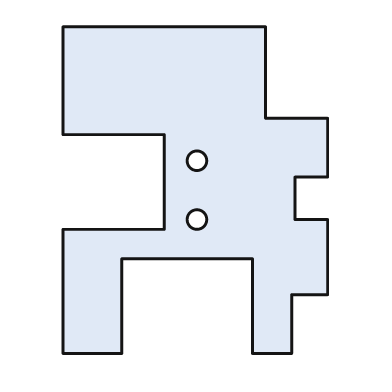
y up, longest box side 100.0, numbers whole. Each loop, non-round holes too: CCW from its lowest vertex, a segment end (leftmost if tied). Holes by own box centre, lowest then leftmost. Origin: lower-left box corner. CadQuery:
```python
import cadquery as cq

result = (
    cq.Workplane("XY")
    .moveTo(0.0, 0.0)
    .lineTo(18.0, 0.0)
    .lineTo(18.0, 29.0)
    .lineTo(58.0, 29.0)
    .lineTo(58.0, 0.0)
    .lineTo(70.0, 0.0)
    .lineTo(70.0, 18.0)
    .lineTo(81.0, 18.0)
    .lineTo(81.0, 41.0)
    .lineTo(71.0, 41.0)
    .lineTo(71.0, 54.0)
    .lineTo(81.0, 54.0)
    .lineTo(81.0, 72.0)
    .lineTo(62.0, 72.0)
    .lineTo(62.0, 100.0)
    .lineTo(0.0, 100.0)
    .lineTo(0.0, 67.0)
    .lineTo(31.0, 67.0)
    .lineTo(31.0, 38.0)
    .lineTo(0.0, 38.0)
    .close()
    .moveTo(41.0, 41.0)
    .circle(3.0)
    .moveTo(41.0, 59.0)
    .circle(3.0)
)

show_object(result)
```